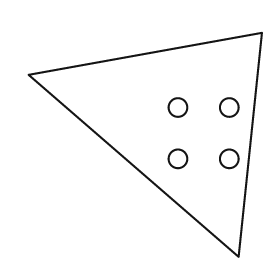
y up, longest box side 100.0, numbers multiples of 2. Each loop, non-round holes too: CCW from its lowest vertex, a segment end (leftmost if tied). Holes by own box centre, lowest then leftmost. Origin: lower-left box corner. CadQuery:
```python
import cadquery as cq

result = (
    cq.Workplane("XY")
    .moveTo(90.0, 0.0)
    .lineTo(100.0, 96.0)
    .lineTo(0.0, 78.0)
    .close()
    .moveTo(64.0, 42.0)
    .circle(4.0)
    .moveTo(86.0, 42.0)
    .circle(4.0)
    .moveTo(64.0, 64.0)
    .circle(4.0)
    .moveTo(86.0, 64.0)
    .circle(4.0)
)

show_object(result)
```